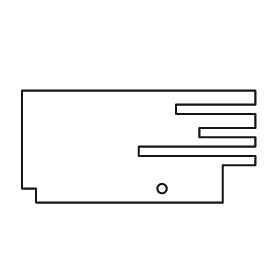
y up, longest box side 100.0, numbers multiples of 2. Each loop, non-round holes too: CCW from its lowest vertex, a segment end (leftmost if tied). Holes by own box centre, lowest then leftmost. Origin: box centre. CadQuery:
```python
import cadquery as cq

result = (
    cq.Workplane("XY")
    .moveTo(-44.0, -24.0)
    .lineTo(36.0, -24.0)
    .lineTo(36.0, -8.0)
    .lineTo(50.0, -8.0)
    .lineTo(50.0, -4.0)
    .lineTo(0.0, -4.0)
    .lineTo(0.0, 0.0)
    .lineTo(50.0, 0.0)
    .lineTo(50.0, 4.0)
    .lineTo(26.0, 4.0)
    .lineTo(26.0, 8.0)
    .lineTo(50.0, 8.0)
    .lineTo(50.0, 14.0)
    .lineTo(16.0, 14.0)
    .lineTo(16.0, 18.0)
    .lineTo(50.0, 18.0)
    .lineTo(50.0, 24.0)
    .lineTo(-50.0, 24.0)
    .lineTo(-50.0, -18.0)
    .lineTo(-44.0, -18.0)
    .close()
    .moveTo(10.0, -18.0)
    .circle(2.0)
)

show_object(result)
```